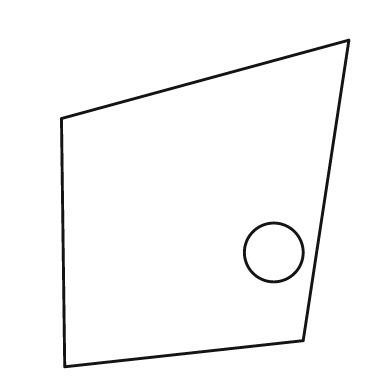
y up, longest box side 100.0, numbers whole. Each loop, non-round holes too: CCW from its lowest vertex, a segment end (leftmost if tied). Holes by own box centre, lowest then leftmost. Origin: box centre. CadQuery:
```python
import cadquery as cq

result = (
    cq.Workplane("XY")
    .moveTo(-43.0, -50.0)
    .lineTo(30.0, -42.0)
    .lineTo(44.0, 50.0)
    .lineTo(-44.0, 26.0)
    .close()
    .moveTo(21.0, -15.0)
    .circle(9.0)
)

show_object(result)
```